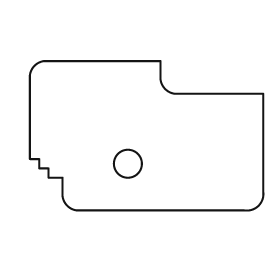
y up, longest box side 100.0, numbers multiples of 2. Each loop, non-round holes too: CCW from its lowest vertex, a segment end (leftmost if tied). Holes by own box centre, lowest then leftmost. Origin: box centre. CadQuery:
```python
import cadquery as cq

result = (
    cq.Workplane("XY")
    .moveTo(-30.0, -32.0)
    .lineTo(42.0, -32.0)
    .threePointArc((48.0, -30.0), (50.0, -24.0))
    .lineTo(50.0, 18.0)
    .lineTo(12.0, 18.0)
    .threePointArc((8.0, 20.0), (6.0, 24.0))
    .lineTo(6.0, 32.0)
    .lineTo(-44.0, 32.0)
    .threePointArc((-48.0, 30.0), (-50.0, 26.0))
    .lineTo(-50.0, -10.0)
    .lineTo(-46.0, -10.0)
    .lineTo(-46.0, -14.0)
    .lineTo(-42.0, -14.0)
    .lineTo(-42.0, -18.0)
    .lineTo(-36.0, -18.0)
    .lineTo(-36.0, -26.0)
    .threePointArc((-34.0, -30.0), (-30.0, -32.0))
    .close()
    .moveTo(-8.0, -12.0)
    .circle(6.0)
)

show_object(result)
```